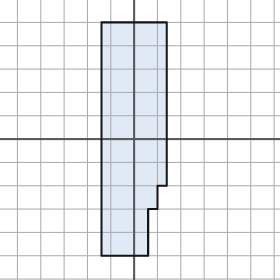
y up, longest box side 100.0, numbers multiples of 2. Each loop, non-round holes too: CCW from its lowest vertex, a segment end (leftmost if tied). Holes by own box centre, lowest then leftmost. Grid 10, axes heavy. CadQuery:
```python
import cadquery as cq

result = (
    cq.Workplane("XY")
    .moveTo(-14.0, -50.0)
    .lineTo(6.0, -50.0)
    .lineTo(6.0, -30.0)
    .lineTo(10.0, -30.0)
    .lineTo(10.0, -20.0)
    .lineTo(14.0, -20.0)
    .lineTo(14.0, 50.0)
    .lineTo(-14.0, 50.0)
    .close()
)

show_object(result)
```